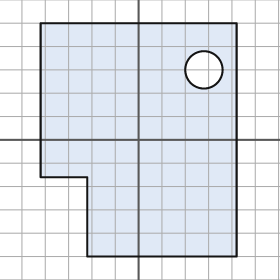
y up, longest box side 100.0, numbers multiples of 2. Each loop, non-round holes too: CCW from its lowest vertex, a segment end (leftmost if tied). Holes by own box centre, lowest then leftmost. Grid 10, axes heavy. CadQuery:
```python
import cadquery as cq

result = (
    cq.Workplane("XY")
    .moveTo(-22.0, -50.0)
    .lineTo(42.0, -50.0)
    .lineTo(42.0, 50.0)
    .lineTo(-42.0, 50.0)
    .lineTo(-42.0, -16.0)
    .lineTo(-22.0, -16.0)
    .close()
    .moveTo(28.0, 30.0)
    .circle(8.0)
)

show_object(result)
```